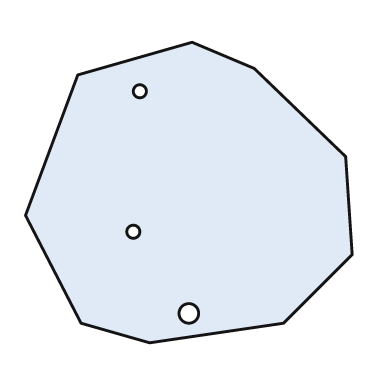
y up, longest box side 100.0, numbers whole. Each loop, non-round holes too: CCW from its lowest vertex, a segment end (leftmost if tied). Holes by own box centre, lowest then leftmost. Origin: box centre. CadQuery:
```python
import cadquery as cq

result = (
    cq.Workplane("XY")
    .moveTo(-12.0, -46.0)
    .lineTo(29.0, -40.0)
    .lineTo(50.0, -19.0)
    .lineTo(48.0, 11.0)
    .lineTo(20.0, 38.0)
    .lineTo(1.0, 46.0)
    .lineTo(-34.0, 36.0)
    .lineTo(-50.0, -7.0)
    .lineTo(-33.0, -40.0)
    .close()
    .moveTo(0.0, -37.0)
    .circle(3.0)
    .moveTo(-17.0, -12.0)
    .circle(2.0)
    .moveTo(-15.0, 31.0)
    .circle(2.0)
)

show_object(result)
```